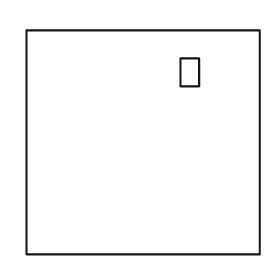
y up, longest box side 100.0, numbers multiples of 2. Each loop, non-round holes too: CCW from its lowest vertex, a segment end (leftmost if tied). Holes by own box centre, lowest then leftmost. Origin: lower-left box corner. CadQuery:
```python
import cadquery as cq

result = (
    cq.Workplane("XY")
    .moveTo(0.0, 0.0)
    .lineTo(100.0, 0.0)
    .lineTo(100.0, 96.0)
    .lineTo(0.0, 96.0)
    .close()
    .moveTo(66.0, 72.0)
    .lineTo(74.0, 72.0)
    .lineTo(74.0, 84.0)
    .lineTo(66.0, 84.0)
    .close()
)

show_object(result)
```